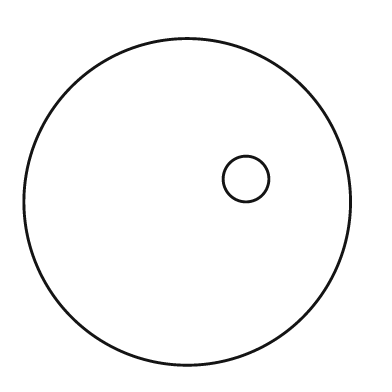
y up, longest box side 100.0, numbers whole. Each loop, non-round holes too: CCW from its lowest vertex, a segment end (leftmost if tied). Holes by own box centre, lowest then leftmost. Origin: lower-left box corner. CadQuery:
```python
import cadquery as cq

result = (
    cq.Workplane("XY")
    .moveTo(50.0, 50.0)
    .circle(50.0)
    .moveTo(68.0, 57.0)
    .circle(7.0)
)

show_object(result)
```